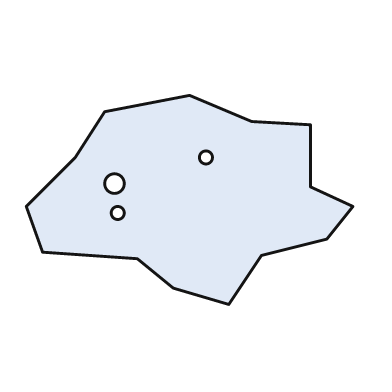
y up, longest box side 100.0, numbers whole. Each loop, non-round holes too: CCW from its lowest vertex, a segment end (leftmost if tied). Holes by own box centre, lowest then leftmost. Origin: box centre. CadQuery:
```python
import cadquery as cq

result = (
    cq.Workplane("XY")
    .moveTo(12.0, -32.0)
    .lineTo(22.0, -17.0)
    .lineTo(42.0, -12.0)
    .lineTo(50.0, -2.0)
    .lineTo(37.0, 4.0)
    .lineTo(37.0, 23.0)
    .lineTo(19.0, 24.0)
    .lineTo(0.0, 32.0)
    .lineTo(-26.0, 27.0)
    .lineTo(-35.0, 13.0)
    .lineTo(-50.0, -2.0)
    .lineTo(-45.0, -16.0)
    .lineTo(-16.0, -18.0)
    .lineTo(-5.0, -27.0)
    .close()
    .moveTo(-22.0, -4.0)
    .circle(2.0)
    .moveTo(-23.0, 5.0)
    .circle(3.0)
    .moveTo(5.0, 13.0)
    .circle(2.0)
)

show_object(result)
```